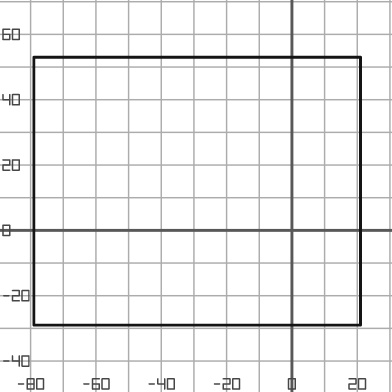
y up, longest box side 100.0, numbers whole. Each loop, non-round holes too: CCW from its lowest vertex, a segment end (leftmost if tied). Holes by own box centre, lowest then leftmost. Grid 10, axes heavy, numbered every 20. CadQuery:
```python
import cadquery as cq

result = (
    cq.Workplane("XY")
    .moveTo(-79.0, -29.0)
    .lineTo(21.0, -29.0)
    .lineTo(21.0, 53.0)
    .lineTo(-79.0, 53.0)
    .close()
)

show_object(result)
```